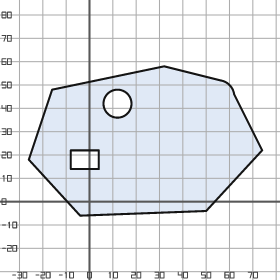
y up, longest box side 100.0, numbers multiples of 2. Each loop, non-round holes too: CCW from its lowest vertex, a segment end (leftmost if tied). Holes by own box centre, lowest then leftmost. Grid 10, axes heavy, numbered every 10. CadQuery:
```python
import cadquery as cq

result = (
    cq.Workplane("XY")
    .moveTo(-4.0, -6.0)
    .lineTo(50.0, -4.0)
    .lineTo(74.0, 22.0)
    .lineTo(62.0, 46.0)
    .threePointArc((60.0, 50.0), (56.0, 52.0))
    .lineTo(32.0, 58.0)
    .lineTo(-16.0, 48.0)
    .lineTo(-26.0, 18.0)
    .close()
    .moveTo(-8.0, 14.0)
    .lineTo(4.0, 14.0)
    .lineTo(4.0, 22.0)
    .lineTo(-8.0, 22.0)
    .close()
    .moveTo(12.0, 42.0)
    .circle(6.0)
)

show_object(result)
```